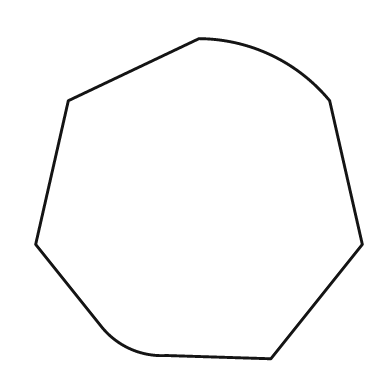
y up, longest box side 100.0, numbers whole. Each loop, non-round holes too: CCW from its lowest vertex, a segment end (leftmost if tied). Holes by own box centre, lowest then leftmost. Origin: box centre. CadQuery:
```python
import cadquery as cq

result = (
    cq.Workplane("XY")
    .moveTo(22.0, -49.0)
    .lineTo(50.0, -14.0)
    .lineTo(40.0, 30.0)
    .threePointArc((22.0, 44.0), (0.0, 49.0))
    .lineTo(-40.0, 30.0)
    .lineTo(-50.0, -14.0)
    .lineTo(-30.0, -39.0)
    .threePointArc((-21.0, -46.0), (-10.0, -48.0))
    .close()
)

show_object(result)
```